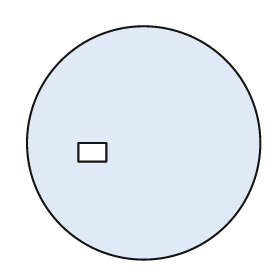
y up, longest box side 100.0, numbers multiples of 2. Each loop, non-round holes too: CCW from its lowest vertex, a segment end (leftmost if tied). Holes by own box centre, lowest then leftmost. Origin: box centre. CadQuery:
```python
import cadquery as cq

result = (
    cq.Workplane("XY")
    .moveTo(0.0, 0.0)
    .circle(50.0)
    .moveTo(-28.0, -8.0)
    .lineTo(-16.0, -8.0)
    .lineTo(-16.0, 0.0)
    .lineTo(-28.0, 0.0)
    .close()
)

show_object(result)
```